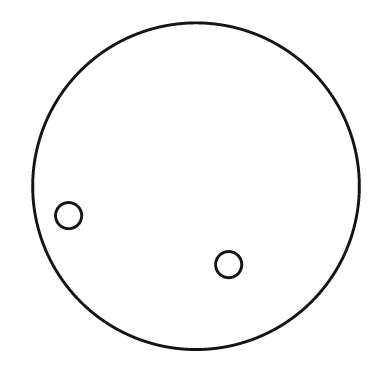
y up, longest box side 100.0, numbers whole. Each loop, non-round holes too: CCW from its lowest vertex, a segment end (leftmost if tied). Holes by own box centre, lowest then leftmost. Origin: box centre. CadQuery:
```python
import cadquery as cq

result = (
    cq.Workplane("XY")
    .moveTo(0.0, 0.0)
    .circle(50.0)
    .moveTo(10.0, -24.0)
    .circle(4.0)
    .moveTo(-39.0, -9.0)
    .circle(4.0)
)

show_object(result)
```